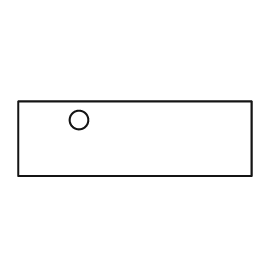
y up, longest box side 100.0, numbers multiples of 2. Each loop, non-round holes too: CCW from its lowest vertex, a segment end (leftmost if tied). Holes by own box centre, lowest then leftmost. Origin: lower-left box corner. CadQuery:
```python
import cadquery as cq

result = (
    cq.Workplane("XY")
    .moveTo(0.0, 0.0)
    .lineTo(100.0, 0.0)
    .lineTo(100.0, 32.0)
    .lineTo(0.0, 32.0)
    .close()
    .moveTo(26.0, 24.0)
    .circle(4.0)
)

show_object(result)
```